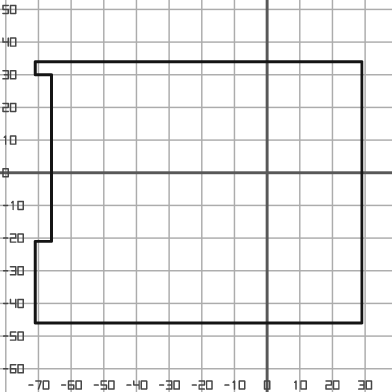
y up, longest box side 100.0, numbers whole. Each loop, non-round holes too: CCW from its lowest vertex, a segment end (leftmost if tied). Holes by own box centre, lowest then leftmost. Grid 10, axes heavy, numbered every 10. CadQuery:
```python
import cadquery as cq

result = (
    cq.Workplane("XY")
    .moveTo(-71.0, -46.0)
    .lineTo(29.0, -46.0)
    .lineTo(29.0, 34.0)
    .lineTo(-71.0, 34.0)
    .lineTo(-71.0, 30.0)
    .lineTo(-66.0, 30.0)
    .lineTo(-66.0, -21.0)
    .lineTo(-71.0, -21.0)
    .close()
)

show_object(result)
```